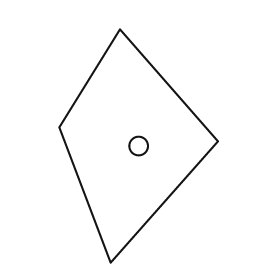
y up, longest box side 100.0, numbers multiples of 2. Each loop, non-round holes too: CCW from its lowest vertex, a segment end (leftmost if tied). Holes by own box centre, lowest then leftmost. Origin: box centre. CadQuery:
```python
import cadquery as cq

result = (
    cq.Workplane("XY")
    .moveTo(-12.0, -50.0)
    .lineTo(34.0, 2.0)
    .lineTo(-8.0, 50.0)
    .lineTo(-34.0, 8.0)
    .close()
    .moveTo(0.0, 0.0)
    .circle(4.0)
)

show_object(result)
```